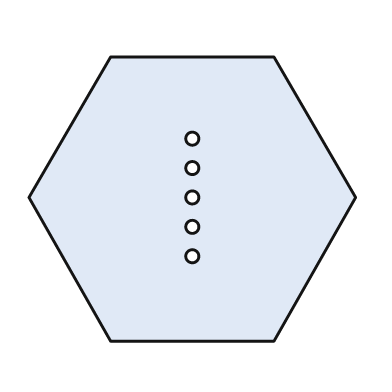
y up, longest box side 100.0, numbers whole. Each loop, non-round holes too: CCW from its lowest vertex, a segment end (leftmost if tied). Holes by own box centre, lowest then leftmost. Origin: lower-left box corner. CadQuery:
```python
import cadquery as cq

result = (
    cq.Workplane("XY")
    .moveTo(25.0, 0.0)
    .lineTo(75.0, 0.0)
    .lineTo(100.0, 44.0)
    .lineTo(75.0, 87.0)
    .lineTo(25.0, 87.0)
    .lineTo(0.0, 44.0)
    .close()
    .moveTo(50.0, 26.0)
    .circle(2.0)
    .moveTo(50.0, 35.0)
    .circle(2.0)
    .moveTo(50.0, 44.0)
    .circle(2.0)
    .moveTo(50.0, 53.0)
    .circle(2.0)
    .moveTo(50.0, 62.0)
    .circle(2.0)
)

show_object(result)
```